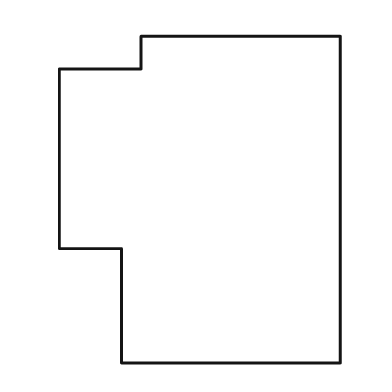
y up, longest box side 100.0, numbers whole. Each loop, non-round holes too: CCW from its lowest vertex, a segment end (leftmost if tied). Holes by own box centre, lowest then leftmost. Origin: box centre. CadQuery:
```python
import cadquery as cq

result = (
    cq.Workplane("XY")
    .moveTo(-24.0, -50.0)
    .lineTo(43.0, -50.0)
    .lineTo(43.0, 50.0)
    .lineTo(-18.0, 50.0)
    .lineTo(-18.0, 40.0)
    .lineTo(-43.0, 40.0)
    .lineTo(-43.0, -15.0)
    .lineTo(-24.0, -15.0)
    .close()
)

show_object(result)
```